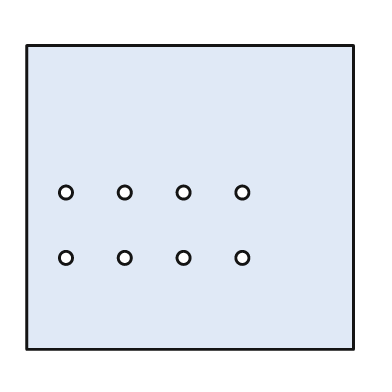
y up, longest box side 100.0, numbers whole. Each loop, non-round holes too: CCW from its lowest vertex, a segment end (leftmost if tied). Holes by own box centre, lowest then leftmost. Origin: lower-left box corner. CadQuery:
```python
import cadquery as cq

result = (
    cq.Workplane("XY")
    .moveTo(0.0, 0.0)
    .lineTo(100.0, 0.0)
    .lineTo(100.0, 93.0)
    .lineTo(0.0, 93.0)
    .close()
    .moveTo(12.0, 28.0)
    .circle(2.0)
    .moveTo(30.0, 28.0)
    .circle(2.0)
    .moveTo(48.0, 28.0)
    .circle(2.0)
    .moveTo(66.0, 28.0)
    .circle(2.0)
    .moveTo(12.0, 48.0)
    .circle(2.0)
    .moveTo(30.0, 48.0)
    .circle(2.0)
    .moveTo(48.0, 48.0)
    .circle(2.0)
    .moveTo(66.0, 48.0)
    .circle(2.0)
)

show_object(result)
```